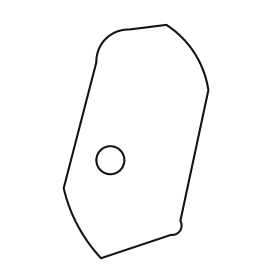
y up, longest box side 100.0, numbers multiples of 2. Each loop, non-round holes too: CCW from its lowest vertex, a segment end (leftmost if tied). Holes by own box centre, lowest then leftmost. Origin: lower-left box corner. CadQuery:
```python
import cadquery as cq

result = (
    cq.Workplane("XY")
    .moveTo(16.0, 0.0)
    .lineTo(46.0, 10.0)
    .threePointArc((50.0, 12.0), (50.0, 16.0))
    .lineTo(62.0, 72.0)
    .threePointArc((56.0, 88.0), (44.0, 100.0))
    .lineTo(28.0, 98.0)
    .threePointArc((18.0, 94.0), (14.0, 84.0))
    .lineTo(0.0, 30.0)
    .threePointArc((6.0, 14.0), (16.0, 0.0))
    .close()
    .moveTo(20.0, 42.0)
    .circle(6.0)
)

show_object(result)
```